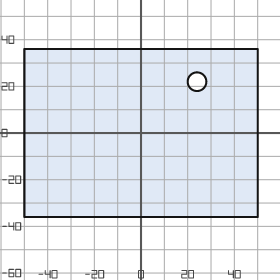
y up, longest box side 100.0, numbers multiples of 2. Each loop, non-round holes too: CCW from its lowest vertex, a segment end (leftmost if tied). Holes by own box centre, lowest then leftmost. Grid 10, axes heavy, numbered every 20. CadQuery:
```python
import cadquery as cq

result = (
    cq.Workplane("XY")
    .moveTo(-50.0, -36.0)
    .lineTo(50.0, -36.0)
    .lineTo(50.0, 36.0)
    .lineTo(-50.0, 36.0)
    .close()
    .moveTo(24.0, 22.0)
    .circle(4.0)
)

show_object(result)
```